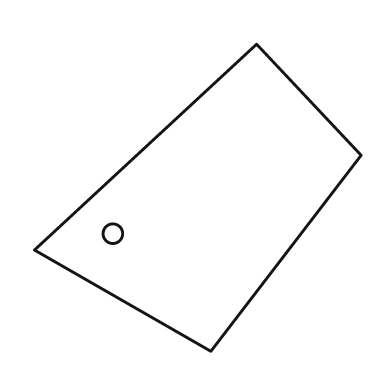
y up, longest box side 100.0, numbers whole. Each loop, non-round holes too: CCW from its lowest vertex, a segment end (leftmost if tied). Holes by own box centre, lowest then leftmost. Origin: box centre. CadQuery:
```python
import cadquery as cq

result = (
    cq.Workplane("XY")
    .moveTo(4.0, -47.0)
    .lineTo(50.0, 13.0)
    .lineTo(18.0, 47.0)
    .lineTo(-50.0, -16.0)
    .close()
    .moveTo(-26.0, -11.0)
    .circle(3.0)
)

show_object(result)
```